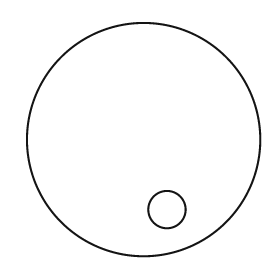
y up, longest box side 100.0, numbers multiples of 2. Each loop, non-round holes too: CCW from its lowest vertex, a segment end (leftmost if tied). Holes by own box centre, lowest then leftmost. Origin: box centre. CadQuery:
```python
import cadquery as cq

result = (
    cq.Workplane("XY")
    .moveTo(0.0, 0.0)
    .circle(50.0)
    .moveTo(10.0, -30.0)
    .circle(8.0)
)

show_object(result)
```